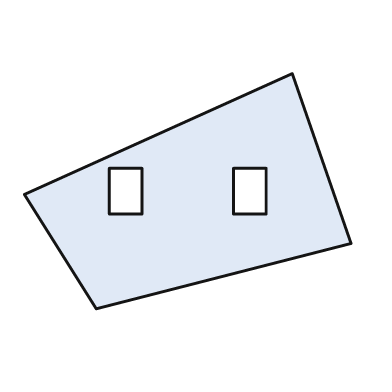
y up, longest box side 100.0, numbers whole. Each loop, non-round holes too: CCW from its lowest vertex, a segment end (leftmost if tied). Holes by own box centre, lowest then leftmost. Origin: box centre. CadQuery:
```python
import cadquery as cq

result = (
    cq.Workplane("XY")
    .moveTo(-28.0, -36.0)
    .lineTo(50.0, -16.0)
    .lineTo(32.0, 36.0)
    .lineTo(-50.0, -1.0)
    .close()
    .moveTo(-24.0, -7.0)
    .lineTo(-14.0, -7.0)
    .lineTo(-14.0, 7.0)
    .lineTo(-24.0, 7.0)
    .close()
    .moveTo(14.0, -7.0)
    .lineTo(24.0, -7.0)
    .lineTo(24.0, 7.0)
    .lineTo(14.0, 7.0)
    .close()
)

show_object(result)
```